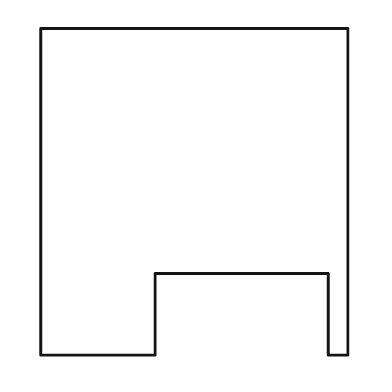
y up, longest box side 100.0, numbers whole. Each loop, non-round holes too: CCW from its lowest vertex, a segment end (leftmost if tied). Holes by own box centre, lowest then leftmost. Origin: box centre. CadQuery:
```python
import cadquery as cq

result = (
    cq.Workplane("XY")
    .moveTo(-47.0, -50.0)
    .lineTo(-12.0, -50.0)
    .lineTo(-12.0, -25.0)
    .lineTo(41.0, -25.0)
    .lineTo(41.0, -50.0)
    .lineTo(47.0, -50.0)
    .lineTo(47.0, 50.0)
    .lineTo(-47.0, 50.0)
    .close()
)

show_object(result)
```